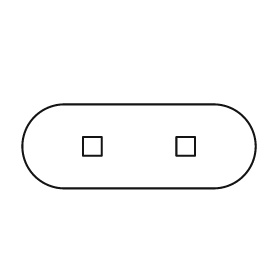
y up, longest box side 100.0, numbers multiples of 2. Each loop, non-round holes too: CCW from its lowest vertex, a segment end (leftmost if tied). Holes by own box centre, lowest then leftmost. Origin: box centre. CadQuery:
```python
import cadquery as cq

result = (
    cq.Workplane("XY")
    .moveTo(-32.0, -18.0)
    .lineTo(32.0, -18.0)
    .threePointArc((50.0, 0.0), (32.0, 18.0))
    .lineTo(-32.0, 18.0)
    .threePointArc((-50.0, 0.0), (-32.0, -18.0))
    .close()
    .moveTo(-24.0, -4.0)
    .lineTo(-16.0, -4.0)
    .lineTo(-16.0, 4.0)
    .lineTo(-24.0, 4.0)
    .close()
    .moveTo(16.0, -4.0)
    .lineTo(24.0, -4.0)
    .lineTo(24.0, 4.0)
    .lineTo(16.0, 4.0)
    .close()
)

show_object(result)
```